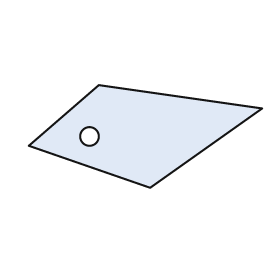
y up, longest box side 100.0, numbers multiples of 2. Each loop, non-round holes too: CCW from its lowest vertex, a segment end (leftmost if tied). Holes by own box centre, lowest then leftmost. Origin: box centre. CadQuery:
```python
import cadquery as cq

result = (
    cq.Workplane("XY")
    .moveTo(2.0, -22.0)
    .lineTo(50.0, 12.0)
    .lineTo(-20.0, 22.0)
    .lineTo(-50.0, -4.0)
    .close()
    .moveTo(-24.0, 0.0)
    .circle(4.0)
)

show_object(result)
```